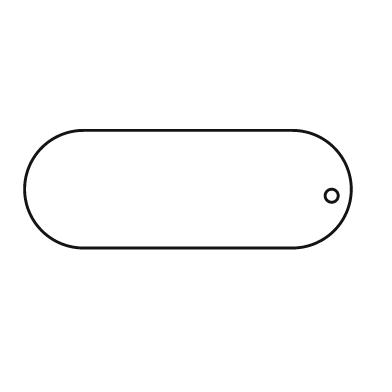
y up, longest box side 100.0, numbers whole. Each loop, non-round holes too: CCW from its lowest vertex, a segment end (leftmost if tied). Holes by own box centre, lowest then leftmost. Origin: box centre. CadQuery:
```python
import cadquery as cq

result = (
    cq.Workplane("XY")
    .moveTo(-32.0, -18.0)
    .lineTo(32.0, -18.0)
    .threePointArc((50.0, 0.0), (32.0, 18.0))
    .lineTo(-32.0, 18.0)
    .threePointArc((-50.0, 0.0), (-32.0, -18.0))
    .close()
    .moveTo(44.0, -2.0)
    .circle(2.0)
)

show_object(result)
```